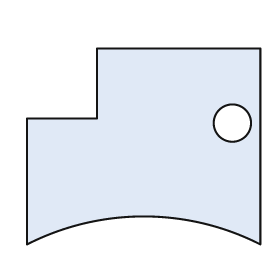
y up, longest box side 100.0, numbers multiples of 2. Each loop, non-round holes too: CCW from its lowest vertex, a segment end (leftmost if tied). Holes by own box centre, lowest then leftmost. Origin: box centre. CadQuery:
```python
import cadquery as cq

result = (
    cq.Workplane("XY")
    .moveTo(-50.0, -42.0)
    .threePointArc((0.0, -30.0), (50.0, -42.0))
    .lineTo(50.0, 42.0)
    .lineTo(-20.0, 42.0)
    .lineTo(-20.0, 12.0)
    .lineTo(-50.0, 12.0)
    .close()
    .moveTo(38.0, 10.0)
    .circle(8.0)
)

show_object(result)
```